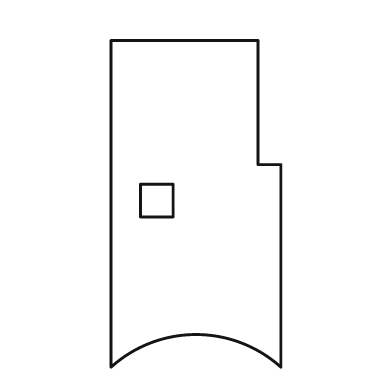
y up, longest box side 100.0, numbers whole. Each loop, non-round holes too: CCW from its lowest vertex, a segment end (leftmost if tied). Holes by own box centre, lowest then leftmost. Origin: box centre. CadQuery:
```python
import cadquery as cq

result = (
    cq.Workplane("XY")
    .moveTo(-26.0, -50.0)
    .threePointArc((0.0, -40.0), (26.0, -50.0))
    .lineTo(26.0, 12.0)
    .lineTo(19.0, 12.0)
    .lineTo(19.0, 50.0)
    .lineTo(-26.0, 50.0)
    .close()
    .moveTo(-17.0, -4.0)
    .lineTo(-7.0, -4.0)
    .lineTo(-7.0, 6.0)
    .lineTo(-17.0, 6.0)
    .close()
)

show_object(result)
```